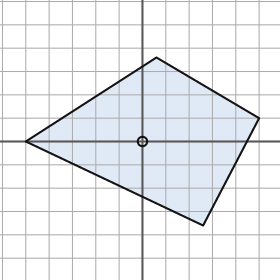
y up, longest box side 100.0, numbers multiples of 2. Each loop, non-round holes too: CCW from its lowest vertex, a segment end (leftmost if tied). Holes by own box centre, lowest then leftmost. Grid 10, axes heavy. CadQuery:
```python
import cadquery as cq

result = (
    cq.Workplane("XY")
    .moveTo(26.0, -36.0)
    .lineTo(50.0, 10.0)
    .lineTo(6.0, 36.0)
    .lineTo(-50.0, 0.0)
    .close()
    .moveTo(0.0, 0.0)
    .circle(2.0)
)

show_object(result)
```